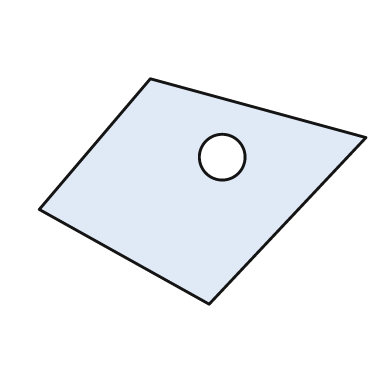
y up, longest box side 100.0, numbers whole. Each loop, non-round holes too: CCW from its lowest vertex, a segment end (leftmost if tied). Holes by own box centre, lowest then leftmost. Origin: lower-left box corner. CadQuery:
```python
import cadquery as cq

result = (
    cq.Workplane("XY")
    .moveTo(52.0, 0.0)
    .lineTo(100.0, 51.0)
    .lineTo(34.0, 69.0)
    .lineTo(0.0, 29.0)
    .close()
    .moveTo(56.0, 45.0)
    .circle(7.0)
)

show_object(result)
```